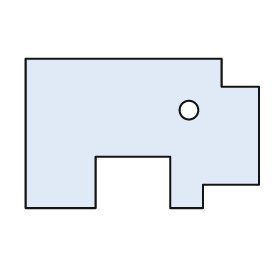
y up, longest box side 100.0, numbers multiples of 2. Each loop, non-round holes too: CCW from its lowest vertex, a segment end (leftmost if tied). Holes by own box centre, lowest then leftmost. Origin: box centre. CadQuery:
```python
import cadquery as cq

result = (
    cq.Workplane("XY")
    .moveTo(-50.0, -32.0)
    .lineTo(-20.0, -32.0)
    .lineTo(-20.0, -10.0)
    .lineTo(12.0, -10.0)
    .lineTo(12.0, -32.0)
    .lineTo(26.0, -32.0)
    .lineTo(26.0, -22.0)
    .lineTo(50.0, -22.0)
    .lineTo(50.0, 20.0)
    .lineTo(34.0, 20.0)
    .lineTo(34.0, 32.0)
    .lineTo(-50.0, 32.0)
    .close()
    .moveTo(20.0, 10.0)
    .circle(4.0)
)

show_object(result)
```